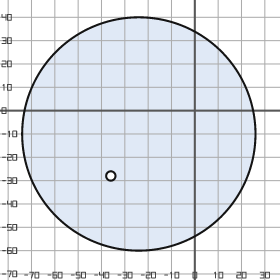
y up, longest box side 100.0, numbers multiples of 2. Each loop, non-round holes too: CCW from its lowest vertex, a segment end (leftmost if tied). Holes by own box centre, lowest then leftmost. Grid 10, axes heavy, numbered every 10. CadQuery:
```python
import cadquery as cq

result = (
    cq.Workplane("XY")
    .moveTo(-24.0, -10.0)
    .circle(50.0)
    .moveTo(-36.0, -28.0)
    .circle(2.0)
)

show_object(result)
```